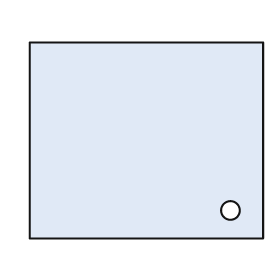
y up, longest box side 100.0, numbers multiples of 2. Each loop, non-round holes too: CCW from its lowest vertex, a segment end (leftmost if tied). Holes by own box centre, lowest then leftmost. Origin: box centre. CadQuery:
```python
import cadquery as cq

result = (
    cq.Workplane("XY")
    .moveTo(-50.0, -42.0)
    .lineTo(50.0, -42.0)
    .lineTo(50.0, 42.0)
    .lineTo(-50.0, 42.0)
    .close()
    .moveTo(36.0, -30.0)
    .circle(4.0)
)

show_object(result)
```